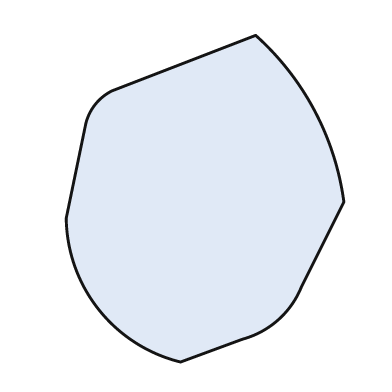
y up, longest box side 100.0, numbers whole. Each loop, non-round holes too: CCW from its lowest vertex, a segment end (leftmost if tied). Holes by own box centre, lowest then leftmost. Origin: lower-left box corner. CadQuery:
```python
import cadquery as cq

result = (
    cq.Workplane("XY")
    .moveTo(35.0, 0.0)
    .lineTo(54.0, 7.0)
    .threePointArc((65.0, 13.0), (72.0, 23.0))
    .lineTo(85.0, 49.0)
    .threePointArc((76.0, 77.0), (58.0, 100.0))
    .lineTo(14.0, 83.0)
    .threePointArc((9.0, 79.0), (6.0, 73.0))
    .lineTo(0.0, 44.0)
    .threePointArc((10.0, 16.0), (35.0, 0.0))
    .close()
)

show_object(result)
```